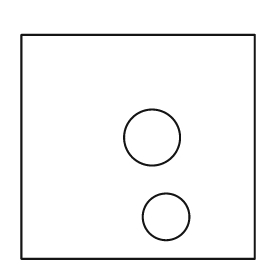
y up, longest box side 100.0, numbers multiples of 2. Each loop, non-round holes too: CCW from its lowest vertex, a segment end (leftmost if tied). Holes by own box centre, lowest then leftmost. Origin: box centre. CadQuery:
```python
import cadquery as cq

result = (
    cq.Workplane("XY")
    .moveTo(-50.0, -48.0)
    .lineTo(50.0, -48.0)
    .lineTo(50.0, 48.0)
    .lineTo(-50.0, 48.0)
    .close()
    .moveTo(12.0, -30.0)
    .circle(10.0)
    .moveTo(6.0, 4.0)
    .circle(12.0)
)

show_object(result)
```